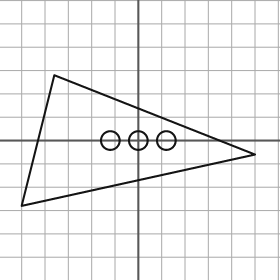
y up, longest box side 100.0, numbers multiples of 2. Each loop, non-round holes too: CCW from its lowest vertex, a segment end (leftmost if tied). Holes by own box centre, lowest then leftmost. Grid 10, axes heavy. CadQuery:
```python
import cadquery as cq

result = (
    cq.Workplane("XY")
    .moveTo(-50.0, -28.0)
    .lineTo(50.0, -6.0)
    .lineTo(-36.0, 28.0)
    .close()
    .moveTo(-12.0, 0.0)
    .circle(4.0)
    .moveTo(0.0, 0.0)
    .circle(4.0)
    .moveTo(12.0, 0.0)
    .circle(4.0)
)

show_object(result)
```